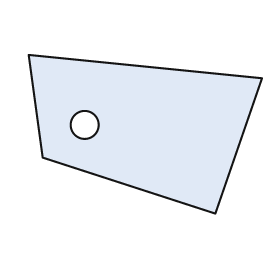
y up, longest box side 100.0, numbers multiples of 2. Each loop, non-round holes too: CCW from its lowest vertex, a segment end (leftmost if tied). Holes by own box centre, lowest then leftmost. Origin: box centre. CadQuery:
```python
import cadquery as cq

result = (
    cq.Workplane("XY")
    .moveTo(30.0, -34.0)
    .lineTo(50.0, 24.0)
    .lineTo(-50.0, 34.0)
    .lineTo(-44.0, -10.0)
    .close()
    .moveTo(-26.0, 4.0)
    .circle(6.0)
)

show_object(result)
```